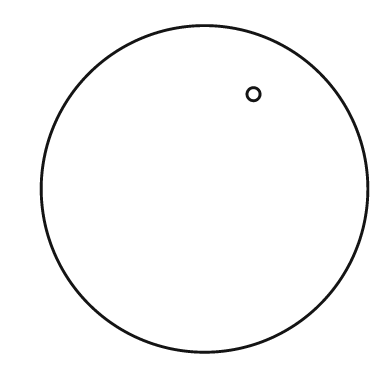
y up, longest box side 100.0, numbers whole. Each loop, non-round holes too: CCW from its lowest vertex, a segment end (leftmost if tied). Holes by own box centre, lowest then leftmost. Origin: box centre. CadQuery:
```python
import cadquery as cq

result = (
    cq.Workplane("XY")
    .moveTo(0.0, 0.0)
    .circle(50.0)
    .moveTo(15.0, 29.0)
    .circle(2.0)
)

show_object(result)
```